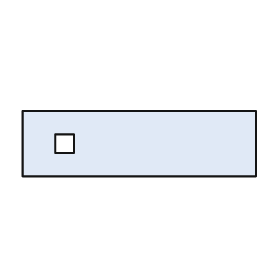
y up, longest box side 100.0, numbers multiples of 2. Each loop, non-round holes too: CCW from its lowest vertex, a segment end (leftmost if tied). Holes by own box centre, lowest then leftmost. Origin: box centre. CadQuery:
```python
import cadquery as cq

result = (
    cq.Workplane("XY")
    .moveTo(-50.0, -14.0)
    .lineTo(50.0, -14.0)
    .lineTo(50.0, 14.0)
    .lineTo(-50.0, 14.0)
    .close()
    .moveTo(-36.0, -4.0)
    .lineTo(-28.0, -4.0)
    .lineTo(-28.0, 4.0)
    .lineTo(-36.0, 4.0)
    .close()
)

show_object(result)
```